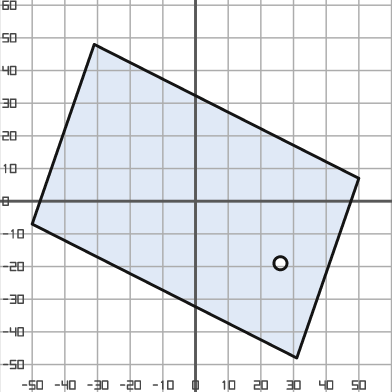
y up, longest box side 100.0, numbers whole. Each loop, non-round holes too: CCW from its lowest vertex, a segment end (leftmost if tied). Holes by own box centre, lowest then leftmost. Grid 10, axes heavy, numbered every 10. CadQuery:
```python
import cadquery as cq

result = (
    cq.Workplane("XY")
    .moveTo(31.0, -48.0)
    .lineTo(50.0, 7.0)
    .lineTo(-31.0, 48.0)
    .lineTo(-50.0, -7.0)
    .close()
    .moveTo(26.0, -19.0)
    .circle(2.0)
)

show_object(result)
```